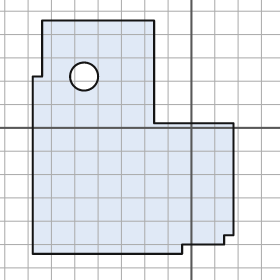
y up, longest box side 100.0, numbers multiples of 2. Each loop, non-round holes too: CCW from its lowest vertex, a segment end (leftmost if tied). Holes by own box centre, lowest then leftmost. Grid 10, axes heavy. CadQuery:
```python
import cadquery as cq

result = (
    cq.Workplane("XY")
    .moveTo(-68.0, -54.0)
    .lineTo(-4.0, -54.0)
    .lineTo(-4.0, -50.0)
    .lineTo(14.0, -50.0)
    .lineTo(14.0, -46.0)
    .lineTo(18.0, -46.0)
    .lineTo(18.0, 2.0)
    .lineTo(-16.0, 2.0)
    .lineTo(-16.0, 46.0)
    .lineTo(-64.0, 46.0)
    .lineTo(-64.0, 22.0)
    .lineTo(-68.0, 22.0)
    .close()
    .moveTo(-46.0, 22.0)
    .circle(6.0)
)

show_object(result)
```